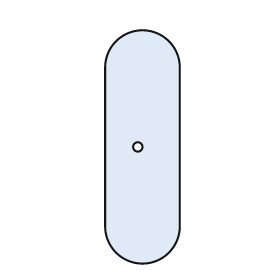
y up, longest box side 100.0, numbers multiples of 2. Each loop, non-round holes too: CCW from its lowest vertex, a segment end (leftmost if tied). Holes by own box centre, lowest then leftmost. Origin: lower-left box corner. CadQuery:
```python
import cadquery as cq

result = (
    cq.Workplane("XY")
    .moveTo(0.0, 16.0)
    .threePointArc((16.0, 0.0), (32.0, 16.0))
    .lineTo(32.0, 84.0)
    .threePointArc((16.0, 100.0), (0.0, 84.0))
    .close()
    .moveTo(14.0, 50.0)
    .circle(2.0)
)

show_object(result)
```